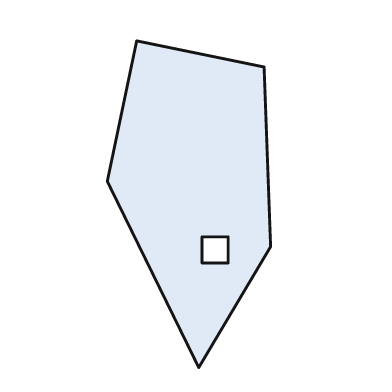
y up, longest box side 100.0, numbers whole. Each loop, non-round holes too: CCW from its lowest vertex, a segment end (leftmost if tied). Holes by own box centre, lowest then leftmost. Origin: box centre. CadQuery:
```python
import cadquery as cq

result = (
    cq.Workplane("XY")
    .moveTo(3.0, -50.0)
    .lineTo(25.0, -13.0)
    .lineTo(23.0, 42.0)
    .lineTo(-16.0, 50.0)
    .lineTo(-25.0, 7.0)
    .close()
    .moveTo(4.0, -18.0)
    .lineTo(12.0, -18.0)
    .lineTo(12.0, -10.0)
    .lineTo(4.0, -10.0)
    .close()
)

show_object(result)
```